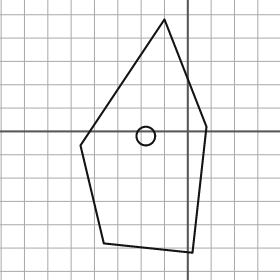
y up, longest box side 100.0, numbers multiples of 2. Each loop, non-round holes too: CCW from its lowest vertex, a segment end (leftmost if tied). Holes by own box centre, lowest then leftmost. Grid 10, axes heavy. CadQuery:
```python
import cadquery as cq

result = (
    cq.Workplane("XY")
    .moveTo(2.0, -52.0)
    .lineTo(8.0, 2.0)
    .lineTo(-10.0, 48.0)
    .lineTo(-46.0, -6.0)
    .lineTo(-36.0, -48.0)
    .close()
    .moveTo(-18.0, -2.0)
    .circle(4.0)
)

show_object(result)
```